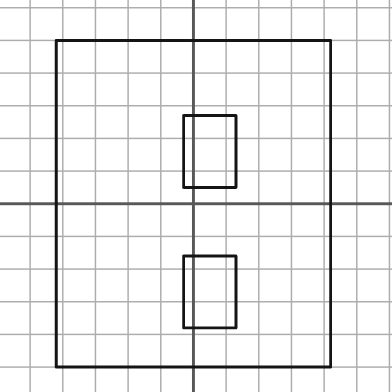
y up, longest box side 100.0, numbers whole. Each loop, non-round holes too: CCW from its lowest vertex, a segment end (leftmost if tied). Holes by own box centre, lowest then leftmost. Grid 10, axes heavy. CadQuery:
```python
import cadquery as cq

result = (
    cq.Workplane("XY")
    .moveTo(-42.0, -50.0)
    .lineTo(42.0, -50.0)
    .lineTo(42.0, 50.0)
    .lineTo(-42.0, 50.0)
    .close()
    .moveTo(-3.0, -38.0)
    .lineTo(13.0, -38.0)
    .lineTo(13.0, -16.0)
    .lineTo(-3.0, -16.0)
    .close()
    .moveTo(-3.0, 5.0)
    .lineTo(13.0, 5.0)
    .lineTo(13.0, 27.0)
    .lineTo(-3.0, 27.0)
    .close()
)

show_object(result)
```